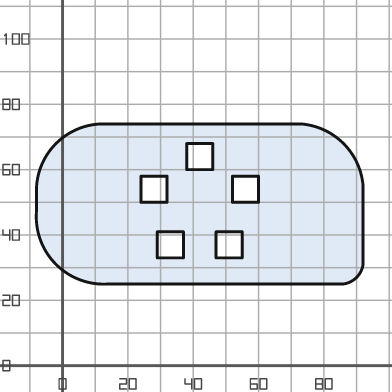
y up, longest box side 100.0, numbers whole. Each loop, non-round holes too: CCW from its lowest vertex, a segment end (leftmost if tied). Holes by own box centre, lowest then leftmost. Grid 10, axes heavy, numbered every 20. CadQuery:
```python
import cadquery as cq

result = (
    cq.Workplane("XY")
    .moveTo(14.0, 25.0)
    .lineTo(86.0, 25.0)
    .threePointArc((90.0, 27.0), (92.0, 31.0))
    .lineTo(92.0, 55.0)
    .threePointArc((86.0, 68.0), (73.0, 74.0))
    .lineTo(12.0, 74.0)
    .threePointArc((-2.0, 68.0), (-8.0, 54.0))
    .lineTo(-8.0, 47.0)
    .threePointArc((-2.0, 31.0), (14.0, 25.0))
    .close()
    .moveTo(29.0, 33.0)
    .lineTo(37.0, 33.0)
    .lineTo(37.0, 41.0)
    .lineTo(29.0, 41.0)
    .close()
    .moveTo(47.0, 33.0)
    .lineTo(55.0, 33.0)
    .lineTo(55.0, 41.0)
    .lineTo(47.0, 41.0)
    .close()
    .moveTo(24.0, 50.0)
    .lineTo(32.0, 50.0)
    .lineTo(32.0, 58.0)
    .lineTo(24.0, 58.0)
    .close()
    .moveTo(52.0, 50.0)
    .lineTo(60.0, 50.0)
    .lineTo(60.0, 58.0)
    .lineTo(52.0, 58.0)
    .close()
    .moveTo(38.0, 60.0)
    .lineTo(46.0, 60.0)
    .lineTo(46.0, 68.0)
    .lineTo(38.0, 68.0)
    .close()
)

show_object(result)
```